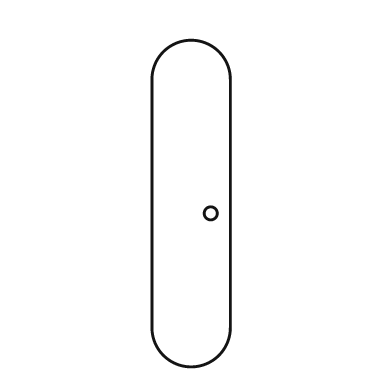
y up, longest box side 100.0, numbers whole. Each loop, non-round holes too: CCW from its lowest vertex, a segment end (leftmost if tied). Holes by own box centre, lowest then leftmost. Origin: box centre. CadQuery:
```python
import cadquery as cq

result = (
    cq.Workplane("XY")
    .moveTo(-12.0, -38.0)
    .threePointArc((0.0, -50.0), (12.0, -38.0))
    .lineTo(12.0, 38.0)
    .threePointArc((0.0, 50.0), (-12.0, 38.0))
    .close()
    .moveTo(6.0, -3.0)
    .circle(2.0)
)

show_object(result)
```